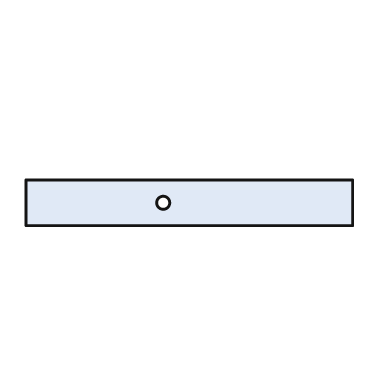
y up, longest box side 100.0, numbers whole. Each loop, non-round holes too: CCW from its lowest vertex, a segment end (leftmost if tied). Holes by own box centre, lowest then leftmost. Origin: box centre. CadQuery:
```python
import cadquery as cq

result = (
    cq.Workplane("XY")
    .moveTo(-50.0, -7.0)
    .lineTo(50.0, -7.0)
    .lineTo(50.0, 7.0)
    .lineTo(-50.0, 7.0)
    .close()
    .moveTo(-8.0, 0.0)
    .circle(2.0)
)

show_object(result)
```